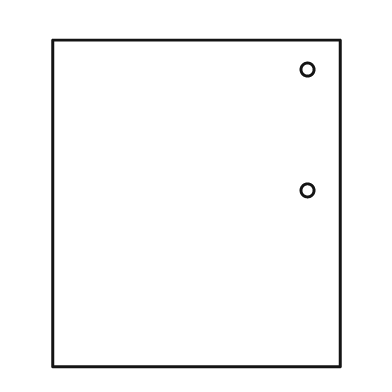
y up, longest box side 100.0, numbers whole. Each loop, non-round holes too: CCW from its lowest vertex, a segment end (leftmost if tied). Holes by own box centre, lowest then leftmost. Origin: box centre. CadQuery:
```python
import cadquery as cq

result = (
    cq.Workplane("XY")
    .moveTo(-44.0, -50.0)
    .lineTo(44.0, -50.0)
    .lineTo(44.0, 50.0)
    .lineTo(-44.0, 50.0)
    .close()
    .moveTo(34.0, 4.0)
    .circle(2.0)
    .moveTo(34.0, 41.0)
    .circle(2.0)
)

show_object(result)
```